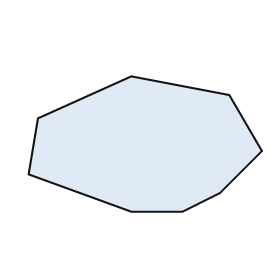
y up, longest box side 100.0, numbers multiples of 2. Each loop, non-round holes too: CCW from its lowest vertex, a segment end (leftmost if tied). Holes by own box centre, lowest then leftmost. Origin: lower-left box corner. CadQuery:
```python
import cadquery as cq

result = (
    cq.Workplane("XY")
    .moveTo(44.0, 0.0)
    .lineTo(66.0, 0.0)
    .lineTo(82.0, 8.0)
    .lineTo(100.0, 26.0)
    .lineTo(86.0, 50.0)
    .lineTo(44.0, 58.0)
    .lineTo(4.0, 40.0)
    .lineTo(0.0, 16.0)
    .close()
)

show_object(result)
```